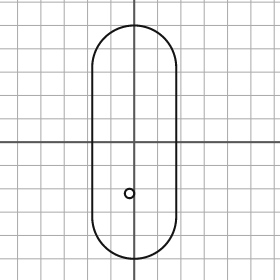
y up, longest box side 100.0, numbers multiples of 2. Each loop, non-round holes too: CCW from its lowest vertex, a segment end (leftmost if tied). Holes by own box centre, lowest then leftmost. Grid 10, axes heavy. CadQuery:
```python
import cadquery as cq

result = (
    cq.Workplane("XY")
    .moveTo(-18.0, -32.0)
    .threePointArc((0.0, -50.0), (18.0, -32.0))
    .lineTo(18.0, 32.0)
    .threePointArc((0.0, 50.0), (-18.0, 32.0))
    .close()
    .moveTo(-2.0, -22.0)
    .circle(2.0)
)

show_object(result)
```